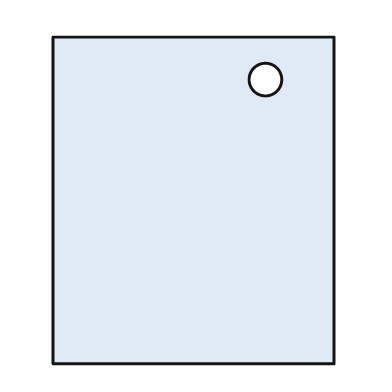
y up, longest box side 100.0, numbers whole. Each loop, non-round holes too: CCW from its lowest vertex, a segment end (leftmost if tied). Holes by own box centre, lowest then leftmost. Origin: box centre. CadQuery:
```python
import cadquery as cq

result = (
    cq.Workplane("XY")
    .moveTo(-43.0, -50.0)
    .lineTo(43.0, -50.0)
    .lineTo(43.0, 50.0)
    .lineTo(-43.0, 50.0)
    .close()
    .moveTo(22.0, 37.0)
    .circle(5.0)
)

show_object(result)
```